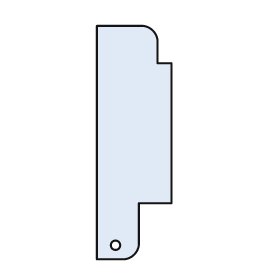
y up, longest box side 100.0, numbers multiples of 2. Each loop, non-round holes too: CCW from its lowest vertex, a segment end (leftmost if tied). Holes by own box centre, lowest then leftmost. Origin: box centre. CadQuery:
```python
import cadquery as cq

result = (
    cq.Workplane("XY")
    .moveTo(-16.0, -50.0)
    .lineTo(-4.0, -50.0)
    .threePointArc((0.0, -48.0), (2.0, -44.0))
    .lineTo(2.0, -26.0)
    .lineTo(16.0, -26.0)
    .lineTo(16.0, 34.0)
    .lineTo(10.0, 34.0)
    .lineTo(10.0, 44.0)
    .threePointArc((8.0, 48.0), (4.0, 50.0))
    .lineTo(-16.0, 50.0)
    .close()
    .moveTo(-8.0, -44.0)
    .circle(2.0)
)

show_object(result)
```